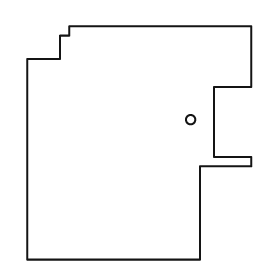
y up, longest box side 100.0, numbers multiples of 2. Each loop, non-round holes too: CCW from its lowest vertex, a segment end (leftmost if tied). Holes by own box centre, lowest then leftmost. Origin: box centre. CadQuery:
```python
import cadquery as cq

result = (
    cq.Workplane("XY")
    .moveTo(-48.0, -50.0)
    .lineTo(26.0, -50.0)
    .lineTo(26.0, -10.0)
    .lineTo(48.0, -10.0)
    .lineTo(48.0, -6.0)
    .lineTo(32.0, -6.0)
    .lineTo(32.0, 24.0)
    .lineTo(48.0, 24.0)
    .lineTo(48.0, 50.0)
    .lineTo(-30.0, 50.0)
    .lineTo(-30.0, 46.0)
    .lineTo(-34.0, 46.0)
    .lineTo(-34.0, 36.0)
    .lineTo(-48.0, 36.0)
    .close()
    .moveTo(22.0, 10.0)
    .circle(2.0)
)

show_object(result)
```